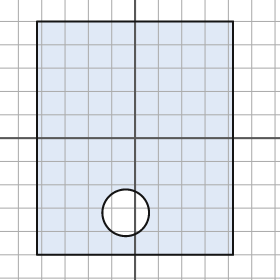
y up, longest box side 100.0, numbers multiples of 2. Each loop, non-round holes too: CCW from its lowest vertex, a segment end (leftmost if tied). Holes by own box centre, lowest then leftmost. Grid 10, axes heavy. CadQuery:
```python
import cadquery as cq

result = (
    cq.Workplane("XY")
    .moveTo(-42.0, -50.0)
    .lineTo(42.0, -50.0)
    .lineTo(42.0, 50.0)
    .lineTo(-42.0, 50.0)
    .close()
    .moveTo(-4.0, -32.0)
    .circle(10.0)
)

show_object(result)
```